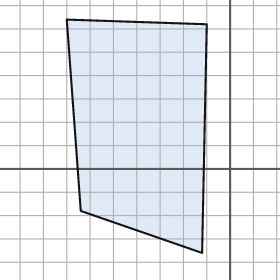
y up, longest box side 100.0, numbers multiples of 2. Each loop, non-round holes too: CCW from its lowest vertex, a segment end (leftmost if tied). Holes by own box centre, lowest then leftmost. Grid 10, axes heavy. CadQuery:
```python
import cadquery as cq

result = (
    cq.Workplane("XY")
    .moveTo(-12.0, -36.0)
    .lineTo(-10.0, 62.0)
    .lineTo(-70.0, 64.0)
    .lineTo(-64.0, -18.0)
    .close()
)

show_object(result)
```